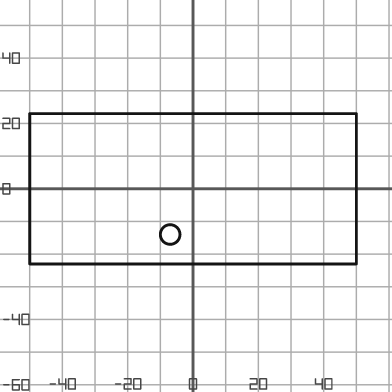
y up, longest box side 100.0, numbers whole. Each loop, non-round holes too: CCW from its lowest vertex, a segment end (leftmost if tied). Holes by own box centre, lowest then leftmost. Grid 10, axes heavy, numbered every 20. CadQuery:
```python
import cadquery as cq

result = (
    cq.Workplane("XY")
    .moveTo(-50.0, -23.0)
    .lineTo(50.0, -23.0)
    .lineTo(50.0, 23.0)
    .lineTo(-50.0, 23.0)
    .close()
    .moveTo(-7.0, -14.0)
    .circle(3.0)
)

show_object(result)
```